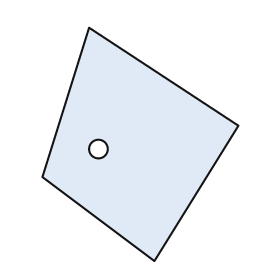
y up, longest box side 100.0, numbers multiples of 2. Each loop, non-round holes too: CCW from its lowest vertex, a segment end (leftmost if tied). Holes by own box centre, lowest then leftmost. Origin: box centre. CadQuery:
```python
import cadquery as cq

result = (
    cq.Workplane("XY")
    .moveTo(6.0, -50.0)
    .lineTo(42.0, 8.0)
    .lineTo(-22.0, 50.0)
    .lineTo(-42.0, -14.0)
    .close()
    .moveTo(-18.0, -2.0)
    .circle(4.0)
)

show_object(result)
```